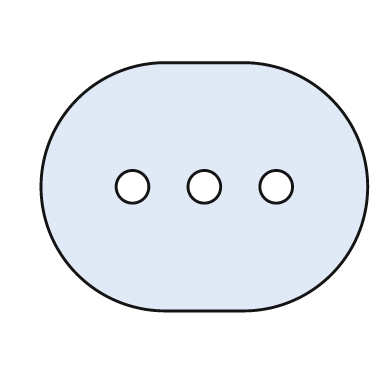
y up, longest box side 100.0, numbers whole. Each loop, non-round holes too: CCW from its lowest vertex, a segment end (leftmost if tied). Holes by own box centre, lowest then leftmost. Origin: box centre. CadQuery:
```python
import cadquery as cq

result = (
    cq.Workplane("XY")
    .moveTo(-12.0, -38.0)
    .lineTo(12.0, -38.0)
    .threePointArc((50.0, 0.0), (12.0, 38.0))
    .lineTo(-12.0, 38.0)
    .threePointArc((-50.0, 0.0), (-12.0, -38.0))
    .close()
    .moveTo(-22.0, 0.0)
    .circle(5.0)
    .moveTo(0.0, 0.0)
    .circle(5.0)
    .moveTo(22.0, 0.0)
    .circle(5.0)
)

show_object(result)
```